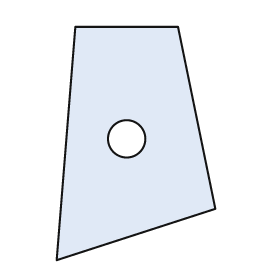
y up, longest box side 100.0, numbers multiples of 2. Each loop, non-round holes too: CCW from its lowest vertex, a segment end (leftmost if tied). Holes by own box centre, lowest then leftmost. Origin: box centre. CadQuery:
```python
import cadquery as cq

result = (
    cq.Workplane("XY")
    .moveTo(-34.0, -50.0)
    .lineTo(34.0, -28.0)
    .lineTo(18.0, 50.0)
    .lineTo(-26.0, 50.0)
    .close()
    .moveTo(-4.0, 2.0)
    .circle(8.0)
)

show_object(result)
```